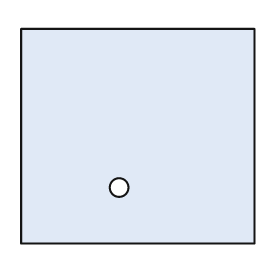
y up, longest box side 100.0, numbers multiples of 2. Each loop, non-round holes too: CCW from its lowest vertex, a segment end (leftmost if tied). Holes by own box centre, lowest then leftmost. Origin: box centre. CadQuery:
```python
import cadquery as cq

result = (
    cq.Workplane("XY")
    .moveTo(-50.0, -46.0)
    .lineTo(50.0, -46.0)
    .lineTo(50.0, 46.0)
    .lineTo(-50.0, 46.0)
    .close()
    .moveTo(-8.0, -22.0)
    .circle(4.0)
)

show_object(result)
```